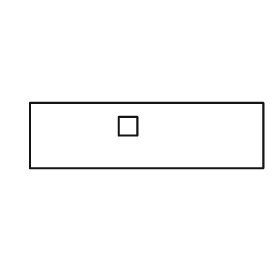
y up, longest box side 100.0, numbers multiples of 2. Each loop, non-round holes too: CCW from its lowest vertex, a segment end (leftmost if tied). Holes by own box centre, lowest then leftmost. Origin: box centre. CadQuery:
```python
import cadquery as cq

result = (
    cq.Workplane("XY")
    .moveTo(-50.0, -14.0)
    .lineTo(50.0, -14.0)
    .lineTo(50.0, 14.0)
    .lineTo(-50.0, 14.0)
    .close()
    .moveTo(-12.0, 0.0)
    .lineTo(-4.0, 0.0)
    .lineTo(-4.0, 8.0)
    .lineTo(-12.0, 8.0)
    .close()
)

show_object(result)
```